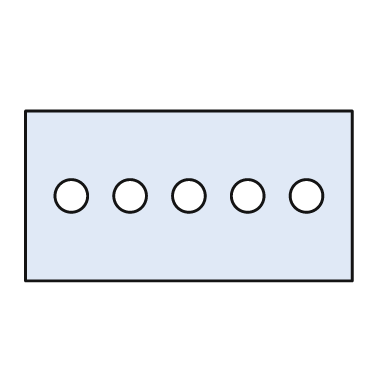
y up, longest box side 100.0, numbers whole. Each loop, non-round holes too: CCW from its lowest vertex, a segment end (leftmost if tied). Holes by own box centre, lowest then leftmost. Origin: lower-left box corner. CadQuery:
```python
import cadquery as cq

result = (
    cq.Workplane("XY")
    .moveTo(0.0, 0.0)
    .lineTo(100.0, 0.0)
    .lineTo(100.0, 52.0)
    .lineTo(0.0, 52.0)
    .close()
    .moveTo(14.0, 26.0)
    .circle(5.0)
    .moveTo(32.0, 26.0)
    .circle(5.0)
    .moveTo(50.0, 26.0)
    .circle(5.0)
    .moveTo(68.0, 26.0)
    .circle(5.0)
    .moveTo(86.0, 26.0)
    .circle(5.0)
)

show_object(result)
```